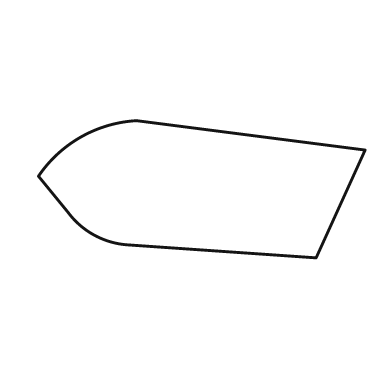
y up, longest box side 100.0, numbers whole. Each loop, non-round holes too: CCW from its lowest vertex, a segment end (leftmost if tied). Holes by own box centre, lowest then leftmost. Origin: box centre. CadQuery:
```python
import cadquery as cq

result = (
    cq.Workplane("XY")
    .moveTo(35.0, -21.0)
    .lineTo(50.0, 12.0)
    .lineTo(-20.0, 21.0)
    .threePointArc((-37.0, 16.0), (-50.0, 4.0))
    .lineTo(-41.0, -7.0)
    .threePointArc((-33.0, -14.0), (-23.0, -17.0))
    .close()
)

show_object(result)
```